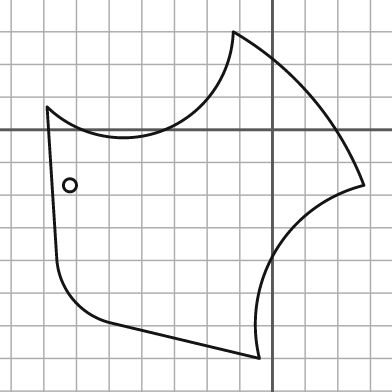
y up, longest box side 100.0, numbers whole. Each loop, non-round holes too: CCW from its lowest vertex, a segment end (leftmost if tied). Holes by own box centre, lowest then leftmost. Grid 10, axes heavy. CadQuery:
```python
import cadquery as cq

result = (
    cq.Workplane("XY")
    .moveTo(-4.0, -70.0)
    .threePointArc((1.0, -37.0), (28.0, -17.0))
    .threePointArc((12.0, 10.0), (-12.0, 30.0))
    .threePointArc((-33.0, 0.0), (-69.0, 7.0))
    .lineTo(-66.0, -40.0)
    .threePointArc((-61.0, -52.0), (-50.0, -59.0))
    .close()
    .moveTo(-62.0, -17.0)
    .circle(2.0)
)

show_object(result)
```